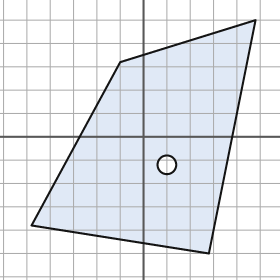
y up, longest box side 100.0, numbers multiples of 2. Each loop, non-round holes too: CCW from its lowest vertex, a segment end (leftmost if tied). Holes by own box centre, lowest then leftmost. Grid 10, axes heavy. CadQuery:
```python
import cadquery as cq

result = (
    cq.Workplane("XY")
    .moveTo(28.0, -50.0)
    .lineTo(48.0, 50.0)
    .lineTo(-10.0, 32.0)
    .lineTo(-48.0, -38.0)
    .close()
    .moveTo(10.0, -12.0)
    .circle(4.0)
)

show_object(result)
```